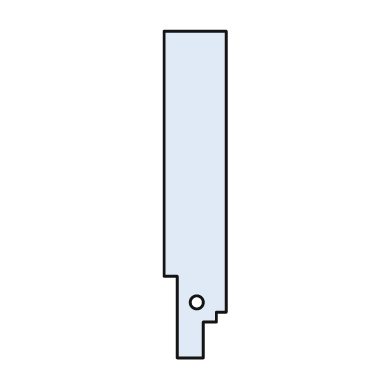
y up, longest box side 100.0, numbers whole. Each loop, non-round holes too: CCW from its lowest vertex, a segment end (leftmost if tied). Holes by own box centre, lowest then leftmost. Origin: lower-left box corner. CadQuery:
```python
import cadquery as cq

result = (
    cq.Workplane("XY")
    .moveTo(4.0, 0.0)
    .lineTo(12.0, 0.0)
    .lineTo(12.0, 11.0)
    .lineTo(16.0, 11.0)
    .lineTo(16.0, 14.0)
    .lineTo(19.0, 14.0)
    .lineTo(19.0, 100.0)
    .lineTo(0.0, 100.0)
    .lineTo(0.0, 25.0)
    .lineTo(4.0, 25.0)
    .close()
    .moveTo(10.0, 17.0)
    .circle(2.0)
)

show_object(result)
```